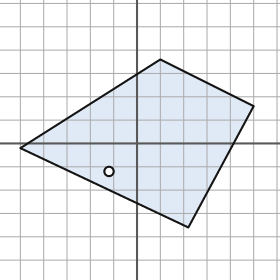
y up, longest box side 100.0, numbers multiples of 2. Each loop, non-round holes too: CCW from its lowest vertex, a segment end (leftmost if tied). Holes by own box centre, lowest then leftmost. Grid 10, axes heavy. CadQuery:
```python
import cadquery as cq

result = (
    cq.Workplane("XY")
    .moveTo(22.0, -36.0)
    .lineTo(50.0, 16.0)
    .lineTo(10.0, 36.0)
    .lineTo(-50.0, -2.0)
    .close()
    .moveTo(-12.0, -12.0)
    .circle(2.0)
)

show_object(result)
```